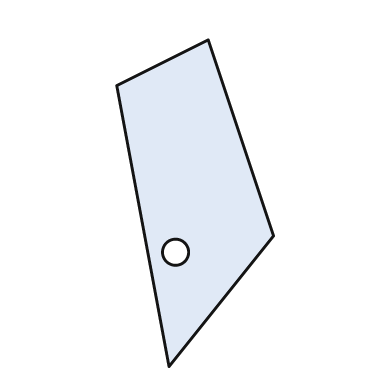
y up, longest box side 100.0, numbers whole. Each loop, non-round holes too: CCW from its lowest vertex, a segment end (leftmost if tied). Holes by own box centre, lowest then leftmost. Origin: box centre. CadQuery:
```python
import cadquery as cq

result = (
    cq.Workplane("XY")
    .moveTo(-8.0, -50.0)
    .lineTo(24.0, -10.0)
    .lineTo(4.0, 50.0)
    .lineTo(-24.0, 36.0)
    .close()
    .moveTo(-6.0, -15.0)
    .circle(4.0)
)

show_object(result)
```